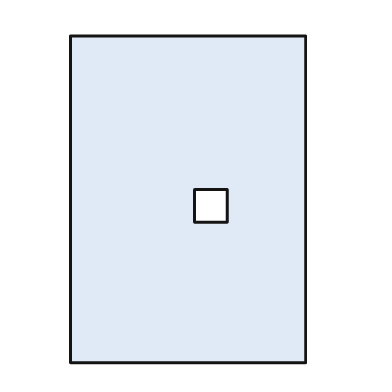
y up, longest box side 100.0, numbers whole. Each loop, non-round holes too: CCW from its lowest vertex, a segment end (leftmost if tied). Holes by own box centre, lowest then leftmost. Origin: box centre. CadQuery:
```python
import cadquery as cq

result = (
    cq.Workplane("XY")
    .moveTo(-36.0, -50.0)
    .lineTo(36.0, -50.0)
    .lineTo(36.0, 50.0)
    .lineTo(-36.0, 50.0)
    .close()
    .moveTo(2.0, -7.0)
    .lineTo(12.0, -7.0)
    .lineTo(12.0, 3.0)
    .lineTo(2.0, 3.0)
    .close()
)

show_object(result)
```